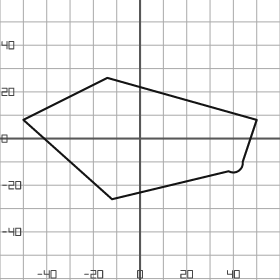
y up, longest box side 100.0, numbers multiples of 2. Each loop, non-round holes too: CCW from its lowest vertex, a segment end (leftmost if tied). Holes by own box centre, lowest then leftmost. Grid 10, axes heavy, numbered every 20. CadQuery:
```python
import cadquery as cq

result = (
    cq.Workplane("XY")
    .moveTo(-12.0, -26.0)
    .lineTo(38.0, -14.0)
    .threePointArc((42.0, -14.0), (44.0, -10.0))
    .lineTo(50.0, 8.0)
    .lineTo(-14.0, 26.0)
    .lineTo(-50.0, 8.0)
    .close()
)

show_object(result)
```